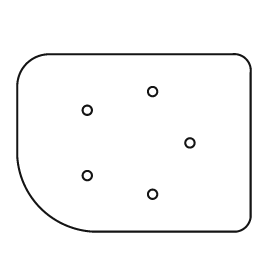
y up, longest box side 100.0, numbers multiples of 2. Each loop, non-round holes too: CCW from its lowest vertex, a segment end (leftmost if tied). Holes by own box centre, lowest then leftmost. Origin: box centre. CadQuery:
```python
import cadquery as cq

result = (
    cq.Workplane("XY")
    .moveTo(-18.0, -38.0)
    .lineTo(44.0, -38.0)
    .threePointArc((48.0, -36.0), (50.0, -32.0))
    .lineTo(50.0, 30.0)
    .threePointArc((48.0, 36.0), (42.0, 38.0))
    .lineTo(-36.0, 38.0)
    .threePointArc((-46.0, 34.0), (-50.0, 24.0))
    .lineTo(-50.0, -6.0)
    .threePointArc((-40.0, -28.0), (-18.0, -38.0))
    .close()
    .moveTo(8.0, -22.0)
    .circle(2.0)
    .moveTo(-20.0, -14.0)
    .circle(2.0)
    .moveTo(24.0, 0.0)
    .circle(2.0)
    .moveTo(-20.0, 14.0)
    .circle(2.0)
    .moveTo(8.0, 22.0)
    .circle(2.0)
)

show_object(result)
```